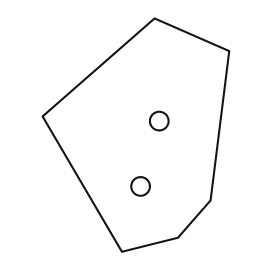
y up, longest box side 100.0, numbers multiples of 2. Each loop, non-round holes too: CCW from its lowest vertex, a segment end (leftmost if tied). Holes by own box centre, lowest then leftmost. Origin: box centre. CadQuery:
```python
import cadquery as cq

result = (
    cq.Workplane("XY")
    .moveTo(-6.0, -50.0)
    .lineTo(18.0, -44.0)
    .lineTo(32.0, -28.0)
    .lineTo(40.0, 36.0)
    .lineTo(8.0, 50.0)
    .lineTo(-40.0, 8.0)
    .close()
    .moveTo(2.0, -22.0)
    .circle(4.0)
    .moveTo(10.0, 6.0)
    .circle(4.0)
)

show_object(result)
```